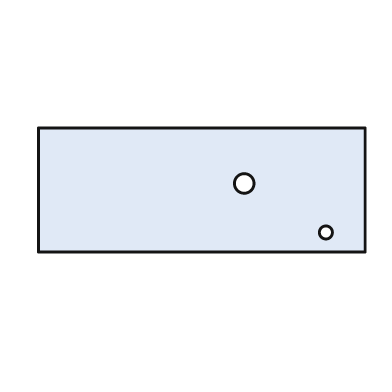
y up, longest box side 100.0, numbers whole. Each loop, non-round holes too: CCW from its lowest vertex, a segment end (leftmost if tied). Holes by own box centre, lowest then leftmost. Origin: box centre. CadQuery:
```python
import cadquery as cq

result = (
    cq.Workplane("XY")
    .moveTo(-50.0, -19.0)
    .lineTo(50.0, -19.0)
    .lineTo(50.0, 19.0)
    .lineTo(-50.0, 19.0)
    .close()
    .moveTo(38.0, -13.0)
    .circle(2.0)
    .moveTo(13.0, 2.0)
    .circle(3.0)
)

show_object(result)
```